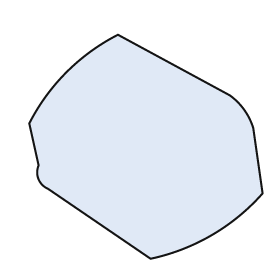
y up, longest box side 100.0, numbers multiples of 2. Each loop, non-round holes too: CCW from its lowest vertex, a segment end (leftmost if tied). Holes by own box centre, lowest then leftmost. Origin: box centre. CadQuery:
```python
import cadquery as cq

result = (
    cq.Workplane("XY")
    .moveTo(2.0, -48.0)
    .threePointArc((28.0, -38.0), (50.0, -20.0))
    .lineTo(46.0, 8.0)
    .threePointArc((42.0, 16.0), (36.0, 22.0))
    .lineTo(-12.0, 48.0)
    .threePointArc((-34.0, 32.0), (-50.0, 10.0))
    .lineTo(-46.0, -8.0)
    .threePointArc((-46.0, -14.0), (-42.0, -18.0))
    .close()
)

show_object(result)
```